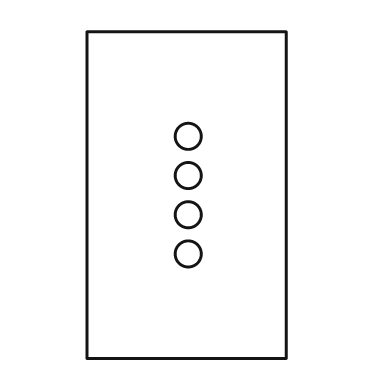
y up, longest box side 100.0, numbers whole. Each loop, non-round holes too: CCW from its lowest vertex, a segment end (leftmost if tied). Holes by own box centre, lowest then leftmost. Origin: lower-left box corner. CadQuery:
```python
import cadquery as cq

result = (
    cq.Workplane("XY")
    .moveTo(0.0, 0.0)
    .lineTo(61.0, 0.0)
    .lineTo(61.0, 100.0)
    .lineTo(0.0, 100.0)
    .close()
    .moveTo(31.0, 32.0)
    .circle(4.0)
    .moveTo(31.0, 44.0)
    .circle(4.0)
    .moveTo(31.0, 56.0)
    .circle(4.0)
    .moveTo(31.0, 68.0)
    .circle(4.0)
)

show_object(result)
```